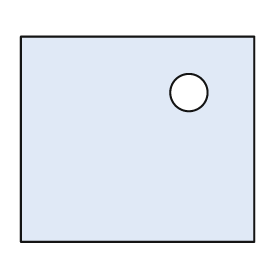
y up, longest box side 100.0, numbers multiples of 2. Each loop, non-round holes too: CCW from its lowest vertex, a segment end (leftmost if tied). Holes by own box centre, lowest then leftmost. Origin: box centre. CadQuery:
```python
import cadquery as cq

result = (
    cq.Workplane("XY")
    .moveTo(-50.0, -44.0)
    .lineTo(50.0, -44.0)
    .lineTo(50.0, 44.0)
    .lineTo(-50.0, 44.0)
    .close()
    .moveTo(22.0, 20.0)
    .circle(8.0)
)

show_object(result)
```